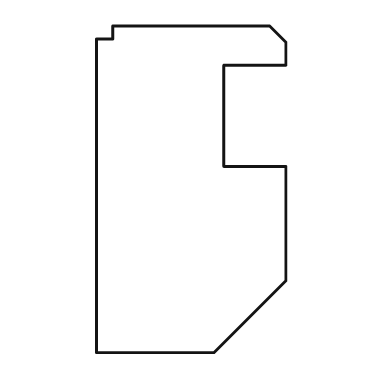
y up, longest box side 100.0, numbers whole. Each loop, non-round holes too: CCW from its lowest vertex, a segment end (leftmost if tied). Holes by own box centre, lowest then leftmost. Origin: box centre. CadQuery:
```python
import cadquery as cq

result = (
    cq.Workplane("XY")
    .moveTo(-29.0, -50.0)
    .lineTo(7.0, -50.0)
    .lineTo(29.0, -28.0)
    .lineTo(29.0, 7.0)
    .lineTo(10.0, 7.0)
    .lineTo(10.0, 38.0)
    .lineTo(29.0, 38.0)
    .lineTo(29.0, 45.0)
    .lineTo(24.0, 50.0)
    .lineTo(-24.0, 50.0)
    .lineTo(-24.0, 46.0)
    .lineTo(-29.0, 46.0)
    .close()
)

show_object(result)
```